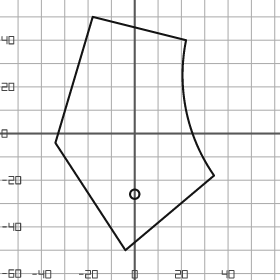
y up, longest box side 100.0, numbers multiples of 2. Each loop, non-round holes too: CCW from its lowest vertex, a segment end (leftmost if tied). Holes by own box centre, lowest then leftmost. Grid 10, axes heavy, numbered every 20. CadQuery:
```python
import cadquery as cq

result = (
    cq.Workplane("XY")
    .moveTo(-4.0, -50.0)
    .lineTo(34.0, -18.0)
    .threePointArc((22.0, 10.0), (22.0, 40.0))
    .lineTo(-18.0, 50.0)
    .lineTo(-34.0, -4.0)
    .close()
    .moveTo(0.0, -26.0)
    .circle(2.0)
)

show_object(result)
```